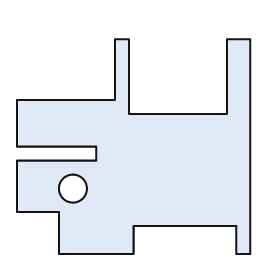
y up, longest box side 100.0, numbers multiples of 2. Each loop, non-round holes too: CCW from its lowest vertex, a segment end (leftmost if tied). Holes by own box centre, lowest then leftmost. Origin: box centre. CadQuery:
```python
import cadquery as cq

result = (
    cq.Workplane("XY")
    .moveTo(-32.0, -46.0)
    .lineTo(0.0, -46.0)
    .lineTo(0.0, -34.0)
    .lineTo(44.0, -34.0)
    .lineTo(44.0, -46.0)
    .lineTo(50.0, -46.0)
    .lineTo(50.0, 46.0)
    .lineTo(40.0, 46.0)
    .lineTo(40.0, 14.0)
    .lineTo(-2.0, 14.0)
    .lineTo(-2.0, 46.0)
    .lineTo(-8.0, 46.0)
    .lineTo(-8.0, 20.0)
    .lineTo(-50.0, 20.0)
    .lineTo(-50.0, 0.0)
    .lineTo(-16.0, 0.0)
    .lineTo(-16.0, -6.0)
    .lineTo(-50.0, -6.0)
    .lineTo(-50.0, -28.0)
    .lineTo(-32.0, -28.0)
    .close()
    .moveTo(-26.0, -18.0)
    .circle(6.0)
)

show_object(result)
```